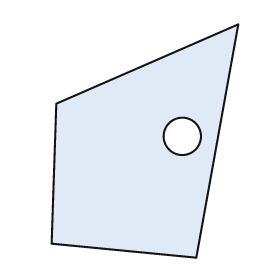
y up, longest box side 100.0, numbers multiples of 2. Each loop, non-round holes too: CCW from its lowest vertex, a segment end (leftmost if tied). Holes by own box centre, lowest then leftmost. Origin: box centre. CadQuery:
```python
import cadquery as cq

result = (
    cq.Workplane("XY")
    .moveTo(22.0, -50.0)
    .lineTo(40.0, 50.0)
    .lineTo(-38.0, 16.0)
    .lineTo(-40.0, -44.0)
    .close()
    .moveTo(16.0, 2.0)
    .circle(8.0)
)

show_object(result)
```